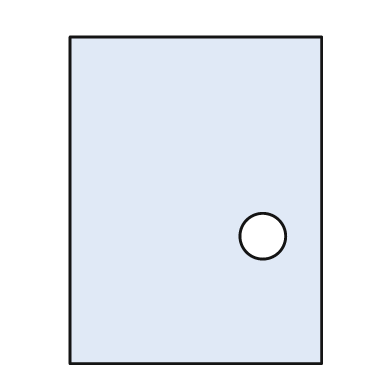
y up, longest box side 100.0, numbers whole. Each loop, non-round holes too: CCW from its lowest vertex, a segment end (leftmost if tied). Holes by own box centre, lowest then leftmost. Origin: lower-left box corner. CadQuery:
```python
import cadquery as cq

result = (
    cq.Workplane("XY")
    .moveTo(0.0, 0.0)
    .lineTo(77.0, 0.0)
    .lineTo(77.0, 100.0)
    .lineTo(0.0, 100.0)
    .close()
    .moveTo(59.0, 39.0)
    .circle(7.0)
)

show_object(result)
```